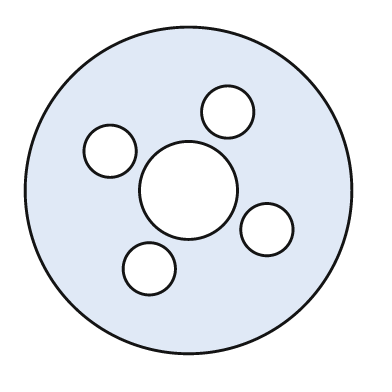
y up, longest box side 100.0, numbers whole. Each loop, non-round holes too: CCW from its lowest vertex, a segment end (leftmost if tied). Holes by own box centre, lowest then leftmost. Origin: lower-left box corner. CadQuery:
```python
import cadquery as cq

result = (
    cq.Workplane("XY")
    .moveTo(50.0, 50.0)
    .circle(50.0)
    .moveTo(38.0, 26.0)
    .circle(8.0)
    .moveTo(74.0, 38.0)
    .circle(8.0)
    .moveTo(50.0, 50.0)
    .circle(15.0)
    .moveTo(26.0, 62.0)
    .circle(8.0)
    .moveTo(62.0, 74.0)
    .circle(8.0)
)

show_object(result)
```